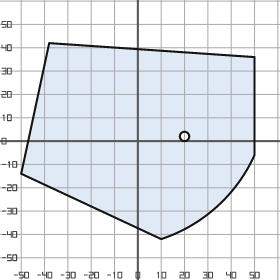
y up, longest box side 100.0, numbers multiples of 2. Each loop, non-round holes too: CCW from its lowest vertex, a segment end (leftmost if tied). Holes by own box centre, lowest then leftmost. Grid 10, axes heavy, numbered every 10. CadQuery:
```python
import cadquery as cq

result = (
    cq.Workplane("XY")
    .moveTo(10.0, -42.0)
    .threePointArc((34.0, -28.0), (50.0, -6.0))
    .lineTo(50.0, 36.0)
    .lineTo(-38.0, 42.0)
    .lineTo(-50.0, -14.0)
    .close()
    .moveTo(20.0, 2.0)
    .circle(2.0)
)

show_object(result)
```